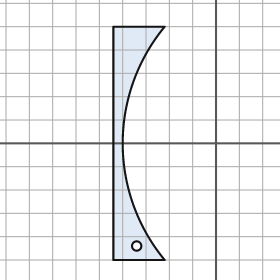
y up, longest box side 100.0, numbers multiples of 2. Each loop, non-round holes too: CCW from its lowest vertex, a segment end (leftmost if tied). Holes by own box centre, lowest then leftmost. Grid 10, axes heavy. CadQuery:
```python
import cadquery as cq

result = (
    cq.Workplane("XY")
    .moveTo(-44.0, -50.0)
    .lineTo(-22.0, -50.0)
    .threePointArc((-40.0, 0.0), (-22.0, 50.0))
    .lineTo(-44.0, 50.0)
    .close()
    .moveTo(-34.0, -44.0)
    .circle(2.0)
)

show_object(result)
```